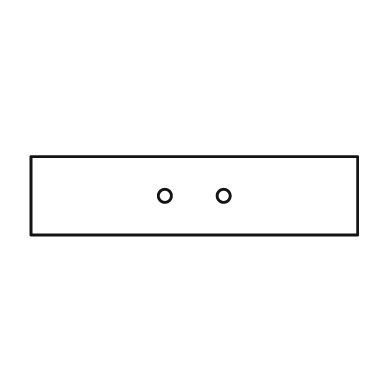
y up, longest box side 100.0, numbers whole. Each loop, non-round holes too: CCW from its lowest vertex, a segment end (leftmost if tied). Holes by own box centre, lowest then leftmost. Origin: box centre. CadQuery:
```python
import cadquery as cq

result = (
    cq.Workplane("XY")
    .moveTo(-50.0, -12.0)
    .lineTo(50.0, -12.0)
    .lineTo(50.0, 12.0)
    .lineTo(-50.0, 12.0)
    .close()
    .moveTo(-9.0, 0.0)
    .circle(2.0)
    .moveTo(9.0, 0.0)
    .circle(2.0)
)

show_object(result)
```